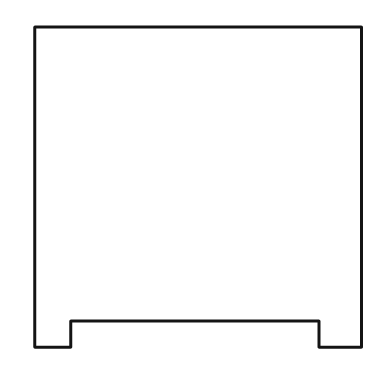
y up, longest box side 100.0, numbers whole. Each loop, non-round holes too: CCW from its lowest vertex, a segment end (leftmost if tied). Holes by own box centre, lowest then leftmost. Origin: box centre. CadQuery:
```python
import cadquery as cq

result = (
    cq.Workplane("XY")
    .moveTo(-50.0, -49.0)
    .lineTo(-39.0, -49.0)
    .lineTo(-39.0, -41.0)
    .lineTo(37.0, -41.0)
    .lineTo(37.0, -49.0)
    .lineTo(50.0, -49.0)
    .lineTo(50.0, 49.0)
    .lineTo(-50.0, 49.0)
    .close()
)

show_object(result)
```